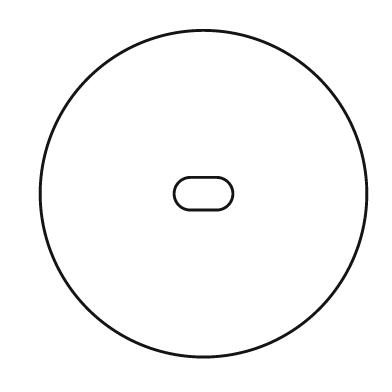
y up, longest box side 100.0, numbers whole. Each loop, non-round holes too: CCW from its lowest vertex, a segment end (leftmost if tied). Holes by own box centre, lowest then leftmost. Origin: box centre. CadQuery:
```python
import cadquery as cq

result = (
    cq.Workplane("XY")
    .moveTo(0.0, 0.0)
    .circle(50.0)
    .moveTo(-4.0, -5.0)
    .lineTo(4.0, -5.0)
    .threePointArc((9.0, 0.0), (4.0, 5.0))
    .lineTo(-4.0, 5.0)
    .threePointArc((-9.0, 0.0), (-4.0, -5.0))
    .close()
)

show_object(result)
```